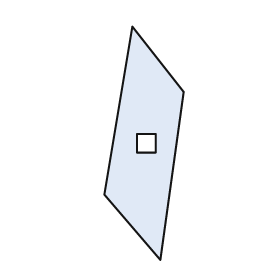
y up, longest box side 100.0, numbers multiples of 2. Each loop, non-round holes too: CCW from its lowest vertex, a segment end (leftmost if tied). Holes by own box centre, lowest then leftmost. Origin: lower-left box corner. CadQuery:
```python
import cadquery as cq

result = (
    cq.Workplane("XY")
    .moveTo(24.0, 0.0)
    .lineTo(34.0, 72.0)
    .lineTo(12.0, 100.0)
    .lineTo(0.0, 28.0)
    .close()
    .moveTo(14.0, 46.0)
    .lineTo(22.0, 46.0)
    .lineTo(22.0, 54.0)
    .lineTo(14.0, 54.0)
    .close()
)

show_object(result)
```